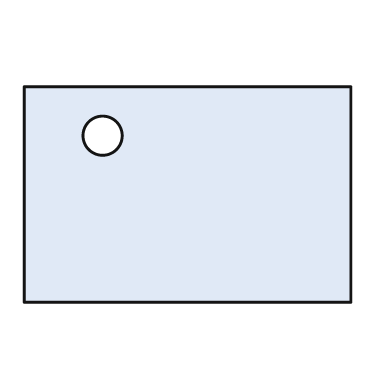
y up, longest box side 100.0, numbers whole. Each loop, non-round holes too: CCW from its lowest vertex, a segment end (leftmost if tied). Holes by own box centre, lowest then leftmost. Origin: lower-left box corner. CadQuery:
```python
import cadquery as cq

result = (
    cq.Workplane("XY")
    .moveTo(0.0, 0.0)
    .lineTo(100.0, 0.0)
    .lineTo(100.0, 66.0)
    .lineTo(0.0, 66.0)
    .close()
    .moveTo(24.0, 51.0)
    .circle(6.0)
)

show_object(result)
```